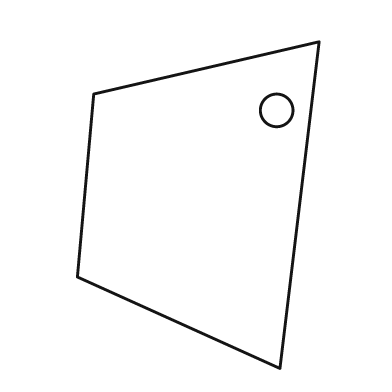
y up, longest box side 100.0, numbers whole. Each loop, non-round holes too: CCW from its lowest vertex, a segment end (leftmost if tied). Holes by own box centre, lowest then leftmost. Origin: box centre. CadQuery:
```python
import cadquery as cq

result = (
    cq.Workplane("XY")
    .moveTo(25.0, -50.0)
    .lineTo(37.0, 50.0)
    .lineTo(-32.0, 34.0)
    .lineTo(-37.0, -22.0)
    .close()
    .moveTo(24.0, 29.0)
    .circle(5.0)
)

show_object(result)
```